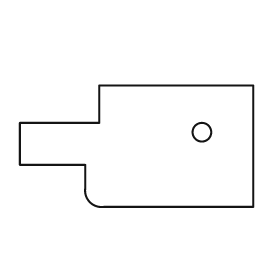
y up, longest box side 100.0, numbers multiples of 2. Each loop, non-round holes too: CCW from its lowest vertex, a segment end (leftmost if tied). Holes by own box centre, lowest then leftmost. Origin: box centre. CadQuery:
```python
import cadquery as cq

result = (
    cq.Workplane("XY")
    .moveTo(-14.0, -26.0)
    .lineTo(50.0, -26.0)
    .lineTo(50.0, 26.0)
    .lineTo(-16.0, 26.0)
    .lineTo(-16.0, 10.0)
    .lineTo(-50.0, 10.0)
    .lineTo(-50.0, -8.0)
    .lineTo(-22.0, -8.0)
    .lineTo(-22.0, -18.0)
    .threePointArc((-20.0, -24.0), (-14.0, -26.0))
    .close()
    .moveTo(28.0, 6.0)
    .circle(4.0)
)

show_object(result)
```